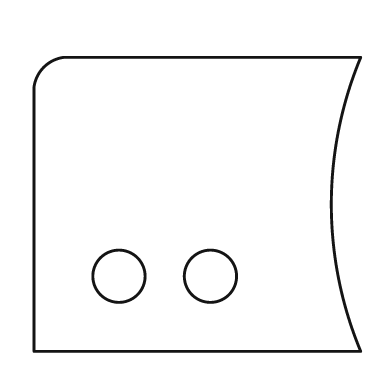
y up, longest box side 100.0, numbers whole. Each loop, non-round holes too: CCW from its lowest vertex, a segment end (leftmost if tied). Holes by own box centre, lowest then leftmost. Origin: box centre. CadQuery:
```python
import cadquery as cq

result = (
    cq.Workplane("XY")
    .moveTo(-50.0, -45.0)
    .lineTo(50.0, -45.0)
    .threePointArc((41.0, 0.0), (50.0, 45.0))
    .lineTo(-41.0, 45.0)
    .threePointArc((-47.0, 42.0), (-50.0, 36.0))
    .close()
    .moveTo(-24.0, -22.0)
    .circle(8.0)
    .moveTo(4.0, -22.0)
    .circle(8.0)
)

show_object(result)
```